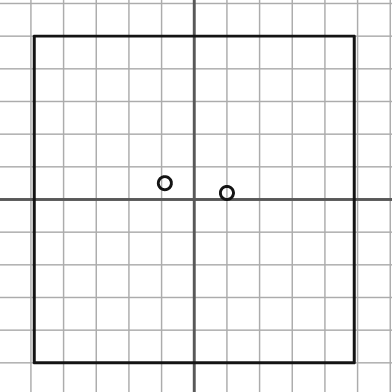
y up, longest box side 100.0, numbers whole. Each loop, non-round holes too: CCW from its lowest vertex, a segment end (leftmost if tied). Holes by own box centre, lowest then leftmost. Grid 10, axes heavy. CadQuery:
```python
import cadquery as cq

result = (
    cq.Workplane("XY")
    .moveTo(-49.0, -50.0)
    .lineTo(49.0, -50.0)
    .lineTo(49.0, 50.0)
    .lineTo(-49.0, 50.0)
    .close()
    .moveTo(10.0, 2.0)
    .circle(2.0)
    .moveTo(-9.0, 5.0)
    .circle(2.0)
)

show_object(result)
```